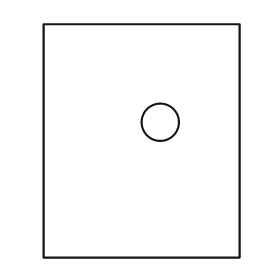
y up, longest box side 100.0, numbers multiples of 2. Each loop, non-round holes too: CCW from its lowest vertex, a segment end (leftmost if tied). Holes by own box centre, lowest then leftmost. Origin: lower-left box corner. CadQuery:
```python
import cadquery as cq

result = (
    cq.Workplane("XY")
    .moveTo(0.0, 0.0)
    .lineTo(84.0, 0.0)
    .lineTo(84.0, 100.0)
    .lineTo(0.0, 100.0)
    .close()
    .moveTo(50.0, 58.0)
    .circle(8.0)
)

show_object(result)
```